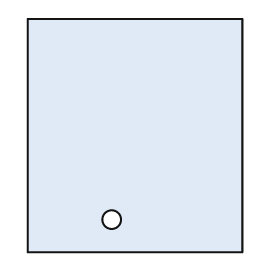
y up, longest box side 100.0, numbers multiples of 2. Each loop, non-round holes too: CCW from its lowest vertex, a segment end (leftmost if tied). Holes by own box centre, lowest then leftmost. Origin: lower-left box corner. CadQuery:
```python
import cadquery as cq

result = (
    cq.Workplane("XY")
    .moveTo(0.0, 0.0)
    .lineTo(92.0, 0.0)
    .lineTo(92.0, 100.0)
    .lineTo(0.0, 100.0)
    .close()
    .moveTo(36.0, 14.0)
    .circle(4.0)
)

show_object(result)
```